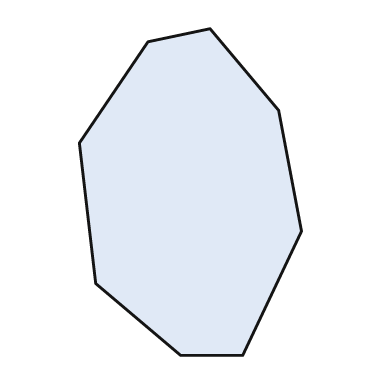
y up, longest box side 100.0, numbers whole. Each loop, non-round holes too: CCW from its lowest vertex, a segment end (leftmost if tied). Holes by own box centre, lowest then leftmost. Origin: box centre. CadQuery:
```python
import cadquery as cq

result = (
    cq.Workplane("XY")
    .moveTo(-3.0, -50.0)
    .lineTo(16.0, -50.0)
    .lineTo(34.0, -12.0)
    .lineTo(27.0, 25.0)
    .lineTo(6.0, 50.0)
    .lineTo(-13.0, 46.0)
    .lineTo(-34.0, 15.0)
    .lineTo(-29.0, -28.0)
    .close()
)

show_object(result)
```